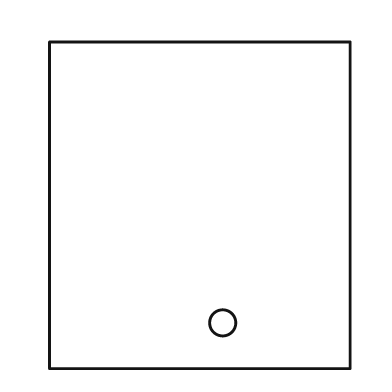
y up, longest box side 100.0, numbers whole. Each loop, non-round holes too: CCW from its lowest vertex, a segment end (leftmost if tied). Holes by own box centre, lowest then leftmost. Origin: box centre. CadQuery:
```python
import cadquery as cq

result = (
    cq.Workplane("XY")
    .moveTo(-46.0, -50.0)
    .lineTo(46.0, -50.0)
    .lineTo(46.0, 50.0)
    .lineTo(-46.0, 50.0)
    .close()
    .moveTo(7.0, -36.0)
    .circle(4.0)
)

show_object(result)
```